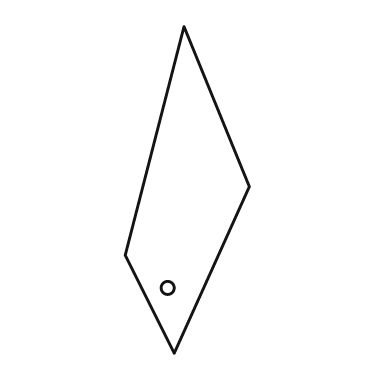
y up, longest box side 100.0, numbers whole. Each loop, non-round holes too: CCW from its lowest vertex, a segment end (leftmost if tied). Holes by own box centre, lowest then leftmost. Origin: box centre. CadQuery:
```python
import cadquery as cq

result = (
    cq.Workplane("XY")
    .moveTo(-4.0, -50.0)
    .lineTo(19.0, 1.0)
    .lineTo(-1.0, 50.0)
    .lineTo(-19.0, -20.0)
    .close()
    .moveTo(-6.0, -30.0)
    .circle(2.0)
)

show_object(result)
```